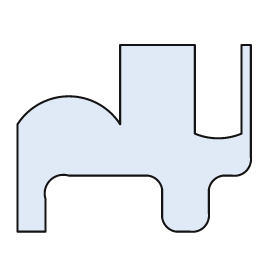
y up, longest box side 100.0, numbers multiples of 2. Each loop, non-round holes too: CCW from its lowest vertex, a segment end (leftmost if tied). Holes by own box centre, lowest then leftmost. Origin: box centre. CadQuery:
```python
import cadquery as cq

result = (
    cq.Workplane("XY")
    .moveTo(-50.0, -40.0)
    .lineTo(-38.0, -40.0)
    .lineTo(-38.0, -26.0)
    .threePointArc((-36.0, -18.0), (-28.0, -16.0))
    .lineTo(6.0, -16.0)
    .threePointArc((10.0, -18.0), (12.0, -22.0))
    .lineTo(12.0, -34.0)
    .threePointArc((14.0, -38.0), (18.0, -40.0))
    .lineTo(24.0, -40.0)
    .threePointArc((30.0, -38.0), (32.0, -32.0))
    .lineTo(32.0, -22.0)
    .threePointArc((34.0, -18.0), (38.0, -16.0))
    .lineTo(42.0, -16.0)
    .threePointArc((48.0, -14.0), (50.0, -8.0))
    .lineTo(50.0, 40.0)
    .lineTo(46.0, 40.0)
    .lineTo(46.0, 2.0)
    .threePointArc((36.0, 0.0), (26.0, 2.0))
    .lineTo(26.0, 40.0)
    .lineTo(-6.0, 40.0)
    .lineTo(-6.0, 6.0)
    .threePointArc((-28.0, 18.0), (-50.0, 6.0))
    .close()
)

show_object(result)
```